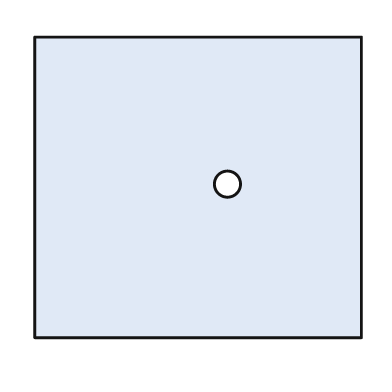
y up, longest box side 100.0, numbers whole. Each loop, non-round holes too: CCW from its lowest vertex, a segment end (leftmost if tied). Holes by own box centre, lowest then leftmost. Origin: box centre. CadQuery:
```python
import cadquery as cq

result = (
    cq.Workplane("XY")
    .moveTo(-50.0, -46.0)
    .lineTo(50.0, -46.0)
    .lineTo(50.0, 46.0)
    .lineTo(-50.0, 46.0)
    .close()
    .moveTo(9.0, 1.0)
    .circle(4.0)
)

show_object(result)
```